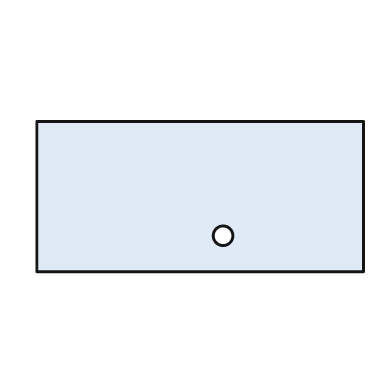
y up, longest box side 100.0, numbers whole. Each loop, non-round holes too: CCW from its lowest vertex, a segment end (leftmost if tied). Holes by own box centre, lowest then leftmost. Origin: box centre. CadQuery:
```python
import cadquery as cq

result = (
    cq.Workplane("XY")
    .moveTo(-50.0, -23.0)
    .lineTo(50.0, -23.0)
    .lineTo(50.0, 23.0)
    .lineTo(-50.0, 23.0)
    .close()
    .moveTo(7.0, -12.0)
    .circle(3.0)
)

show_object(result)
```